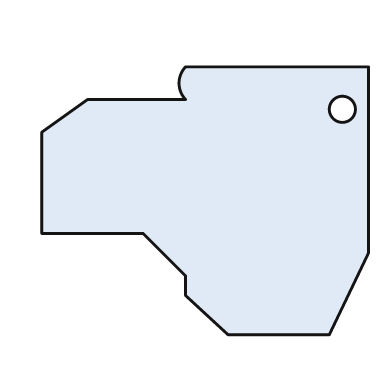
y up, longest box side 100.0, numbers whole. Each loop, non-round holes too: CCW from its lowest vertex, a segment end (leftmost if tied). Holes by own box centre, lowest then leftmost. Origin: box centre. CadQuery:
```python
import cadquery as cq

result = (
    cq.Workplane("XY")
    .moveTo(7.0, -41.0)
    .lineTo(38.0, -41.0)
    .lineTo(50.0, -16.0)
    .lineTo(50.0, 41.0)
    .lineTo(-6.0, 41.0)
    .threePointArc((-8.0, 36.0), (-6.0, 31.0))
    .lineTo(-36.0, 31.0)
    .lineTo(-50.0, 21.0)
    .lineTo(-50.0, -10.0)
    .lineTo(-19.0, -10.0)
    .lineTo(-6.0, -23.0)
    .lineTo(-6.0, -29.0)
    .close()
    .moveTo(42.0, 28.0)
    .circle(4.0)
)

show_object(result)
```